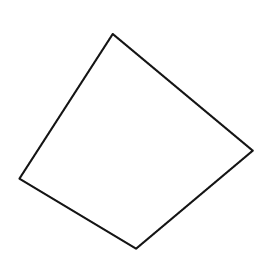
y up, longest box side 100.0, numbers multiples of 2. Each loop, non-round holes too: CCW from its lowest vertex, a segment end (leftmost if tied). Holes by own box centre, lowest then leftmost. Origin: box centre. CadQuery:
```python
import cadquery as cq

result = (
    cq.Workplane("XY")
    .moveTo(0.0, -46.0)
    .lineTo(50.0, -4.0)
    .lineTo(-10.0, 46.0)
    .lineTo(-50.0, -16.0)
    .close()
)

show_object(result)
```